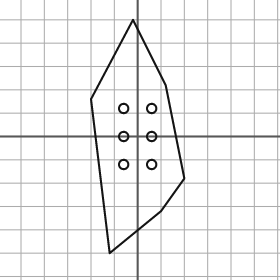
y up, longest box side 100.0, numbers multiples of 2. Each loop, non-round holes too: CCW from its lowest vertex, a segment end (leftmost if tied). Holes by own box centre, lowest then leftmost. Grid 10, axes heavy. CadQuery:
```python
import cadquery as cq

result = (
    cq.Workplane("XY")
    .moveTo(-12.0, -50.0)
    .lineTo(10.0, -32.0)
    .lineTo(20.0, -18.0)
    .lineTo(12.0, 22.0)
    .lineTo(-2.0, 50.0)
    .lineTo(-20.0, 16.0)
    .close()
    .moveTo(-6.0, -12.0)
    .circle(2.0)
    .moveTo(6.0, -12.0)
    .circle(2.0)
    .moveTo(-6.0, 0.0)
    .circle(2.0)
    .moveTo(6.0, 0.0)
    .circle(2.0)
    .moveTo(-6.0, 12.0)
    .circle(2.0)
    .moveTo(6.0, 12.0)
    .circle(2.0)
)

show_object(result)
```